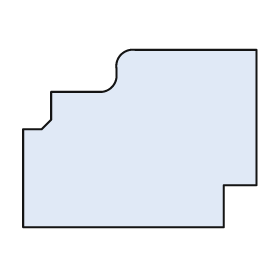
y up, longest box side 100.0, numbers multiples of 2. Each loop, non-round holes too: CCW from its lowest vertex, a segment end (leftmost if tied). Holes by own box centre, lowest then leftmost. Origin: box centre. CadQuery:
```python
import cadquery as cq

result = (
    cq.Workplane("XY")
    .moveTo(-50.0, -38.0)
    .lineTo(36.0, -38.0)
    .lineTo(36.0, -20.0)
    .lineTo(50.0, -20.0)
    .lineTo(50.0, 38.0)
    .lineTo(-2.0, 38.0)
    .threePointArc((-8.0, 36.0), (-10.0, 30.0))
    .lineTo(-10.0, 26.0)
    .threePointArc((-12.0, 22.0), (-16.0, 20.0))
    .lineTo(-38.0, 20.0)
    .lineTo(-38.0, 8.0)
    .lineTo(-42.0, 4.0)
    .lineTo(-50.0, 4.0)
    .close()
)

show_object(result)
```